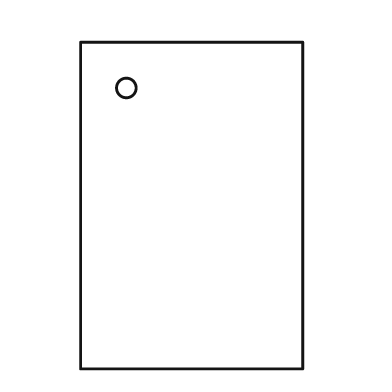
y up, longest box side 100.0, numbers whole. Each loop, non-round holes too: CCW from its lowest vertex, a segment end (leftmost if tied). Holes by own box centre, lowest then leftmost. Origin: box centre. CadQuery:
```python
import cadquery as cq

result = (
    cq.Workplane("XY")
    .moveTo(-34.0, -50.0)
    .lineTo(34.0, -50.0)
    .lineTo(34.0, 50.0)
    .lineTo(-34.0, 50.0)
    .close()
    .moveTo(-20.0, 36.0)
    .circle(3.0)
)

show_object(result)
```